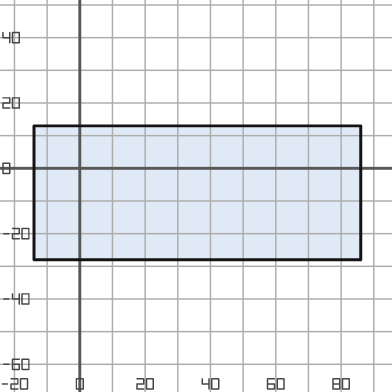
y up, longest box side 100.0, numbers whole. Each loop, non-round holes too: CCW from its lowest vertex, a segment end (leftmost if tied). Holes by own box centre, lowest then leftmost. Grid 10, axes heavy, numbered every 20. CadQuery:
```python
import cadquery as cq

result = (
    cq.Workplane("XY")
    .moveTo(-14.0, -28.0)
    .lineTo(86.0, -28.0)
    .lineTo(86.0, 13.0)
    .lineTo(-14.0, 13.0)
    .close()
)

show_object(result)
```